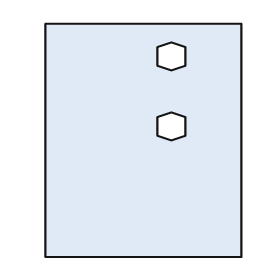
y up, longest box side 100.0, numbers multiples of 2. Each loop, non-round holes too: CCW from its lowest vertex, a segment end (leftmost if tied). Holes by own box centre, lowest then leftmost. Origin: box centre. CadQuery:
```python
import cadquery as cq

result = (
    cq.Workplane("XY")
    .moveTo(-42.0, -50.0)
    .lineTo(42.0, -50.0)
    .lineTo(42.0, 50.0)
    .lineTo(-42.0, 50.0)
    .close()
    .moveTo(12.0, 0.0)
    .lineTo(18.0, 2.0)
    .lineTo(18.0, 10.0)
    .lineTo(12.0, 12.0)
    .lineTo(6.0, 10.0)
    .lineTo(6.0, 2.0)
    .close()
    .moveTo(12.0, 30.0)
    .lineTo(18.0, 32.0)
    .lineTo(18.0, 40.0)
    .lineTo(12.0, 42.0)
    .lineTo(6.0, 40.0)
    .lineTo(6.0, 32.0)
    .close()
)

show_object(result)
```